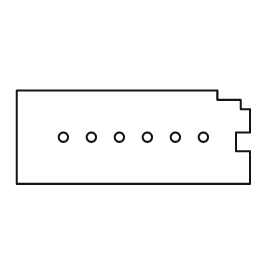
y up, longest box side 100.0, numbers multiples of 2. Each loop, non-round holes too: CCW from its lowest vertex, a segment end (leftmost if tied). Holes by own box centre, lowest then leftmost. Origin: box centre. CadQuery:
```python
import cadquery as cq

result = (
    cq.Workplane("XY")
    .moveTo(-50.0, -20.0)
    .lineTo(50.0, -20.0)
    .lineTo(50.0, -6.0)
    .lineTo(44.0, -6.0)
    .lineTo(44.0, 2.0)
    .lineTo(50.0, 2.0)
    .lineTo(50.0, 12.0)
    .lineTo(46.0, 12.0)
    .lineTo(46.0, 16.0)
    .lineTo(36.0, 16.0)
    .lineTo(36.0, 20.0)
    .lineTo(-50.0, 20.0)
    .close()
    .moveTo(-30.0, 0.0)
    .circle(2.0)
    .moveTo(-18.0, 0.0)
    .circle(2.0)
    .moveTo(-6.0, 0.0)
    .circle(2.0)
    .moveTo(6.0, 0.0)
    .circle(2.0)
    .moveTo(18.0, 0.0)
    .circle(2.0)
    .moveTo(30.0, 0.0)
    .circle(2.0)
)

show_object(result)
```